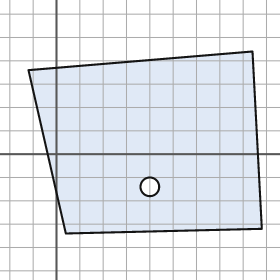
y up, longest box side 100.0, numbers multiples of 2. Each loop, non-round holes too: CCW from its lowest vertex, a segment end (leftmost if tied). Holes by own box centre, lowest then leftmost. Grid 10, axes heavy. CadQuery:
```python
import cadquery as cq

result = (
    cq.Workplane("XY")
    .moveTo(4.0, -34.0)
    .lineTo(88.0, -32.0)
    .lineTo(84.0, 44.0)
    .lineTo(-12.0, 36.0)
    .close()
    .moveTo(40.0, -14.0)
    .circle(4.0)
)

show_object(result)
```